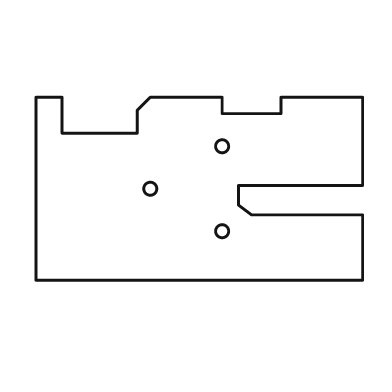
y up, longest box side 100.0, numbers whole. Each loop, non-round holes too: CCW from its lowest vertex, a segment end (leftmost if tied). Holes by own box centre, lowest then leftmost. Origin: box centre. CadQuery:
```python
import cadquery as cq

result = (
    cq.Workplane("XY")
    .moveTo(-50.0, -28.0)
    .lineTo(50.0, -28.0)
    .lineTo(50.0, -8.0)
    .lineTo(16.0, -8.0)
    .lineTo(12.0, -5.0)
    .lineTo(12.0, 1.0)
    .lineTo(50.0, 1.0)
    .lineTo(50.0, 28.0)
    .lineTo(25.0, 28.0)
    .lineTo(25.0, 23.0)
    .lineTo(7.0, 23.0)
    .lineTo(7.0, 28.0)
    .lineTo(-15.0, 28.0)
    .lineTo(-19.0, 24.0)
    .lineTo(-19.0, 17.0)
    .lineTo(-42.0, 17.0)
    .lineTo(-42.0, 28.0)
    .lineTo(-50.0, 28.0)
    .close()
    .moveTo(7.0, -13.0)
    .circle(2.0)
    .moveTo(-15.0, 0.0)
    .circle(2.0)
    .moveTo(7.0, 13.0)
    .circle(2.0)
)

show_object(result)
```